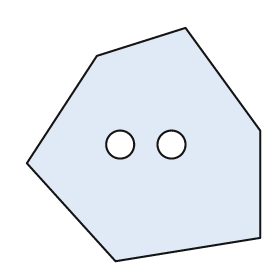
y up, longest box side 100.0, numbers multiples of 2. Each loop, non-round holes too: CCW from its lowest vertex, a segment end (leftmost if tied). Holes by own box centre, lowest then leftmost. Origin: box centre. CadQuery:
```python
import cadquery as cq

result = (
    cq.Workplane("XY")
    .moveTo(-12.0, -50.0)
    .lineTo(50.0, -40.0)
    .lineTo(50.0, 6.0)
    .lineTo(18.0, 50.0)
    .lineTo(-20.0, 38.0)
    .lineTo(-50.0, -8.0)
    .close()
    .moveTo(-10.0, 0.0)
    .circle(6.0)
    .moveTo(12.0, 0.0)
    .circle(6.0)
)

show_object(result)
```